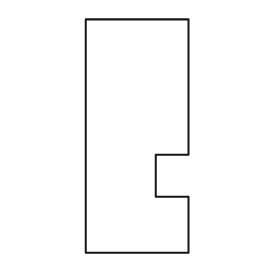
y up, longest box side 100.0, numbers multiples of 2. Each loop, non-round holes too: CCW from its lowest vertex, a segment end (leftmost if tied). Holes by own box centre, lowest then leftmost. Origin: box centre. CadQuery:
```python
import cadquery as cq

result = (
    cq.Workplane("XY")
    .moveTo(-22.0, -50.0)
    .lineTo(22.0, -50.0)
    .lineTo(22.0, -26.0)
    .lineTo(8.0, -26.0)
    .lineTo(8.0, -8.0)
    .lineTo(22.0, -8.0)
    .lineTo(22.0, 50.0)
    .lineTo(-22.0, 50.0)
    .close()
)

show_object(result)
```